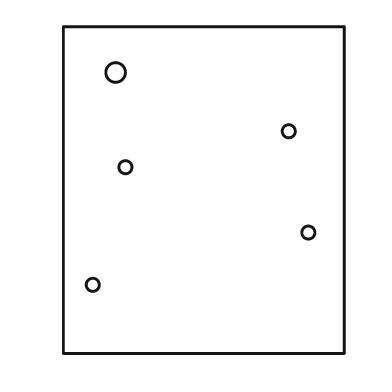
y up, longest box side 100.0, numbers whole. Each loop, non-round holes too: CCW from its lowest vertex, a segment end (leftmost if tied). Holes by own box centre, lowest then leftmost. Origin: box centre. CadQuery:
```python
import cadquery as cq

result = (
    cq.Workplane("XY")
    .moveTo(-43.0, -50.0)
    .lineTo(43.0, -50.0)
    .lineTo(43.0, 50.0)
    .lineTo(-43.0, 50.0)
    .close()
    .moveTo(-34.0, -29.0)
    .circle(2.0)
    .moveTo(32.0, -13.0)
    .circle(2.0)
    .moveTo(-24.0, 7.0)
    .circle(2.0)
    .moveTo(26.0, 18.0)
    .circle(2.0)
    .moveTo(-27.0, 36.0)
    .circle(3.0)
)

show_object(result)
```